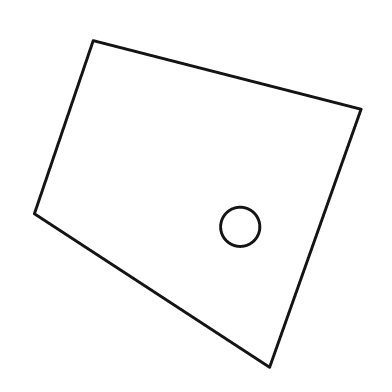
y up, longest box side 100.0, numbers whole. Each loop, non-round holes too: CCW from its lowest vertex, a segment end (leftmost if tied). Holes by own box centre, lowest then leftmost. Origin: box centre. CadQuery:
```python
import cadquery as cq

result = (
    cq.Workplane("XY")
    .moveTo(22.0, -50.0)
    .lineTo(50.0, 29.0)
    .lineTo(-32.0, 50.0)
    .lineTo(-50.0, -3.0)
    .close()
    .moveTo(13.0, -7.0)
    .circle(6.0)
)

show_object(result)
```